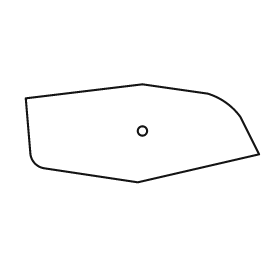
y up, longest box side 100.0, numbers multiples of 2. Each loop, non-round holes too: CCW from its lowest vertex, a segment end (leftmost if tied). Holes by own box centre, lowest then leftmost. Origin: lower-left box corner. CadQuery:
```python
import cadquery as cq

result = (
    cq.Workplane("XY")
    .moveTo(48.0, 0.0)
    .lineTo(100.0, 12.0)
    .lineTo(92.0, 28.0)
    .threePointArc((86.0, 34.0), (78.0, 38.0))
    .lineTo(50.0, 42.0)
    .lineTo(0.0, 36.0)
    .lineTo(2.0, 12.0)
    .threePointArc((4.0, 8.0), (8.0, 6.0))
    .close()
    .moveTo(50.0, 22.0)
    .circle(2.0)
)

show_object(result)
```